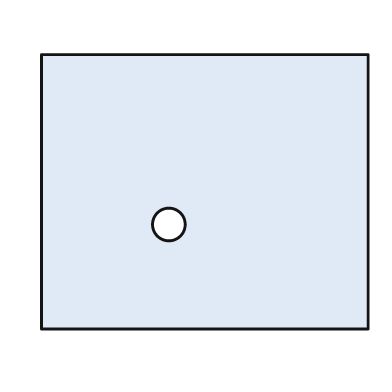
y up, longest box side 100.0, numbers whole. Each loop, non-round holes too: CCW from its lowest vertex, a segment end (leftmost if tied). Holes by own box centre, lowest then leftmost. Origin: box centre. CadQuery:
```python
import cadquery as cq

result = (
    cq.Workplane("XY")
    .moveTo(-50.0, -42.0)
    .lineTo(50.0, -42.0)
    .lineTo(50.0, 42.0)
    .lineTo(-50.0, 42.0)
    .close()
    .moveTo(-11.0, -10.0)
    .circle(5.0)
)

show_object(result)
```